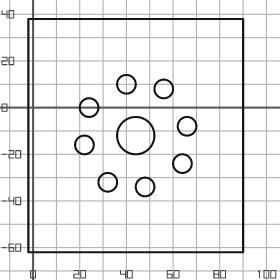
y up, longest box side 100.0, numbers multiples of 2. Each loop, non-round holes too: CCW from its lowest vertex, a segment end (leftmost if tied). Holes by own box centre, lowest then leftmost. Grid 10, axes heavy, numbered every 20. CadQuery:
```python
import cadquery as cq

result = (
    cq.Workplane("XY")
    .moveTo(-2.0, -62.0)
    .lineTo(90.0, -62.0)
    .lineTo(90.0, 38.0)
    .lineTo(-2.0, 38.0)
    .close()
    .moveTo(48.0, -34.0)
    .circle(4.0)
    .moveTo(32.0, -32.0)
    .circle(4.0)
    .moveTo(64.0, -24.0)
    .circle(4.0)
    .moveTo(22.0, -16.0)
    .circle(4.0)
    .moveTo(44.0, -12.0)
    .circle(8.0)
    .moveTo(66.0, -8.0)
    .circle(4.0)
    .moveTo(24.0, 0.0)
    .circle(4.0)
    .moveTo(56.0, 8.0)
    .circle(4.0)
    .moveTo(40.0, 10.0)
    .circle(4.0)
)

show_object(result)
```